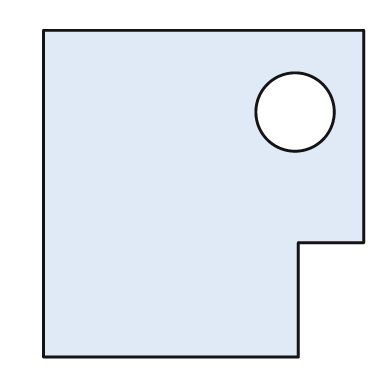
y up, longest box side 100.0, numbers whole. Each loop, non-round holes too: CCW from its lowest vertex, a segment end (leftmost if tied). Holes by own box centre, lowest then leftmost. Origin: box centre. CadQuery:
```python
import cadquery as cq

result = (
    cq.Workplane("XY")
    .moveTo(-49.0, -50.0)
    .lineTo(29.0, -50.0)
    .lineTo(29.0, -15.0)
    .lineTo(49.0, -15.0)
    .lineTo(49.0, 50.0)
    .lineTo(-49.0, 50.0)
    .close()
    .moveTo(28.0, 25.0)
    .circle(12.0)
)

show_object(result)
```